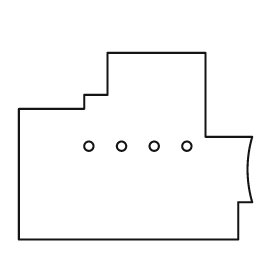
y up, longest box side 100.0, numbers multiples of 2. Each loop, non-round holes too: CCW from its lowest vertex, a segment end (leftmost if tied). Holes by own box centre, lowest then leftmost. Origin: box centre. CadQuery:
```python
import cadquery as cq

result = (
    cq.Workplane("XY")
    .moveTo(-50.0, -40.0)
    .lineTo(44.0, -40.0)
    .lineTo(44.0, -24.0)
    .lineTo(50.0, -24.0)
    .threePointArc((48.0, -10.0), (50.0, 4.0))
    .lineTo(30.0, 4.0)
    .lineTo(30.0, 40.0)
    .lineTo(-12.0, 40.0)
    .lineTo(-12.0, 22.0)
    .lineTo(-22.0, 22.0)
    .lineTo(-22.0, 16.0)
    .lineTo(-50.0, 16.0)
    .close()
    .moveTo(-20.0, 0.0)
    .circle(2.0)
    .moveTo(-6.0, 0.0)
    .circle(2.0)
    .moveTo(8.0, 0.0)
    .circle(2.0)
    .moveTo(22.0, 0.0)
    .circle(2.0)
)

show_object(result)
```